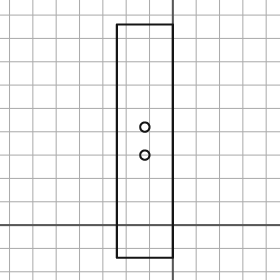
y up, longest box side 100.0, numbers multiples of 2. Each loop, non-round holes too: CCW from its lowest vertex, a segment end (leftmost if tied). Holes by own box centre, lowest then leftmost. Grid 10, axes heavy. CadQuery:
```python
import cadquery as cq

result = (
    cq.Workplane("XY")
    .moveTo(-24.0, -14.0)
    .lineTo(0.0, -14.0)
    .lineTo(0.0, 86.0)
    .lineTo(-24.0, 86.0)
    .close()
    .moveTo(-12.0, 30.0)
    .circle(2.0)
    .moveTo(-12.0, 42.0)
    .circle(2.0)
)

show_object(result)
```